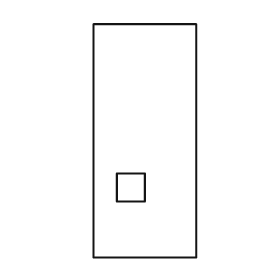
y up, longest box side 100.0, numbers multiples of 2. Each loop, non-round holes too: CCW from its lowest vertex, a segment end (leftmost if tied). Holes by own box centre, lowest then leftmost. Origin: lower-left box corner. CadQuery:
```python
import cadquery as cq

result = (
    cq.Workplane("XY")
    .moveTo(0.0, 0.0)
    .lineTo(44.0, 0.0)
    .lineTo(44.0, 100.0)
    .lineTo(0.0, 100.0)
    .close()
    .moveTo(10.0, 24.0)
    .lineTo(22.0, 24.0)
    .lineTo(22.0, 36.0)
    .lineTo(10.0, 36.0)
    .close()
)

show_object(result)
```